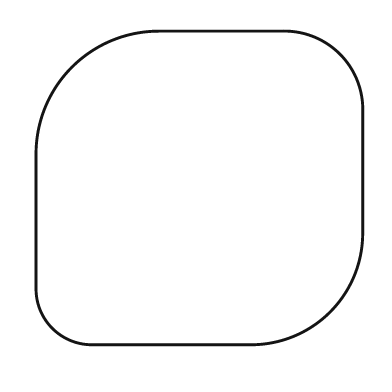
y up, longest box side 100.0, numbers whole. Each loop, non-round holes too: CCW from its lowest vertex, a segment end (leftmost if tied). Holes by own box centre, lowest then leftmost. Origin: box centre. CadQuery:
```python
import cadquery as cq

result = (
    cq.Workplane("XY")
    .moveTo(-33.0, -48.0)
    .lineTo(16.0, -48.0)
    .threePointArc((40.0, -38.0), (50.0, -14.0))
    .lineTo(50.0, 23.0)
    .threePointArc((43.0, 41.0), (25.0, 48.0))
    .lineTo(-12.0, 48.0)
    .threePointArc((-39.0, 37.0), (-50.0, 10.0))
    .lineTo(-50.0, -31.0)
    .threePointArc((-45.0, -43.0), (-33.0, -48.0))
    .close()
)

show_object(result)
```